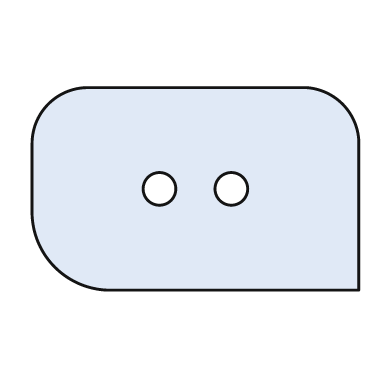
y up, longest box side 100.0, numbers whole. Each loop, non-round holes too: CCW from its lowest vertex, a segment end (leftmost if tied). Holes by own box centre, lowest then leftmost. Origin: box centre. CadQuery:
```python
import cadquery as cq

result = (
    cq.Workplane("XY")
    .moveTo(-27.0, -31.0)
    .lineTo(50.0, -31.0)
    .lineTo(50.0, 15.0)
    .threePointArc((45.0, 26.0), (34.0, 31.0))
    .lineTo(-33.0, 31.0)
    .threePointArc((-45.0, 26.0), (-50.0, 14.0))
    .lineTo(-50.0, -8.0)
    .threePointArc((-43.0, -24.0), (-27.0, -31.0))
    .close()
    .moveTo(-11.0, 0.0)
    .circle(5.0)
    .moveTo(11.0, 0.0)
    .circle(5.0)
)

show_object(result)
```